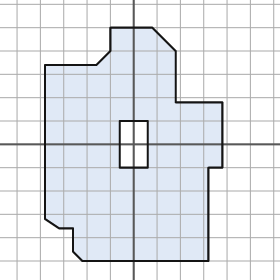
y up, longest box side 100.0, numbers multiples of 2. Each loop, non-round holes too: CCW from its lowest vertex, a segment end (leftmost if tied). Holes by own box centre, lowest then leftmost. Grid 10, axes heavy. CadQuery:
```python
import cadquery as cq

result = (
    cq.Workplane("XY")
    .moveTo(-22.0, -50.0)
    .lineTo(32.0, -50.0)
    .lineTo(32.0, -10.0)
    .lineTo(38.0, -10.0)
    .lineTo(38.0, 18.0)
    .lineTo(18.0, 18.0)
    .lineTo(18.0, 40.0)
    .lineTo(8.0, 50.0)
    .lineTo(-10.0, 50.0)
    .lineTo(-10.0, 40.0)
    .lineTo(-16.0, 34.0)
    .lineTo(-38.0, 34.0)
    .lineTo(-38.0, -32.0)
    .lineTo(-32.0, -36.0)
    .lineTo(-26.0, -36.0)
    .lineTo(-26.0, -46.0)
    .close()
    .moveTo(-6.0, -10.0)
    .lineTo(6.0, -10.0)
    .lineTo(6.0, 10.0)
    .lineTo(-6.0, 10.0)
    .close()
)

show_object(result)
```